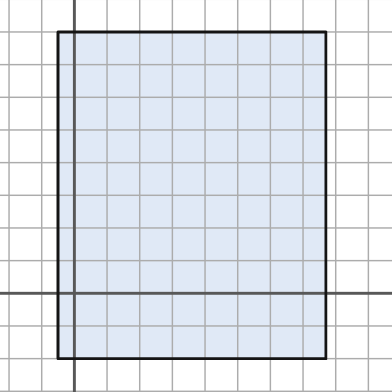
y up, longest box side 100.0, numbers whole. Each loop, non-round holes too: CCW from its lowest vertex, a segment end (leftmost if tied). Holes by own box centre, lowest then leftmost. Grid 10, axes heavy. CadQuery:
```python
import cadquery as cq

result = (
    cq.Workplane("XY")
    .moveTo(-5.0, -20.0)
    .lineTo(77.0, -20.0)
    .lineTo(77.0, 80.0)
    .lineTo(-5.0, 80.0)
    .close()
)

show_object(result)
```